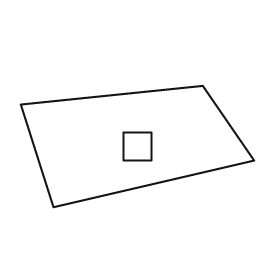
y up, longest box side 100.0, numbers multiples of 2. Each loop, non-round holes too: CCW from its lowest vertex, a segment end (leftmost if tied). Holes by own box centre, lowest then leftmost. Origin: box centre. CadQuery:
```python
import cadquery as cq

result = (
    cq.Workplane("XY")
    .moveTo(-36.0, -26.0)
    .lineTo(50.0, -6.0)
    .lineTo(28.0, 26.0)
    .lineTo(-50.0, 18.0)
    .close()
    .moveTo(-6.0, -6.0)
    .lineTo(6.0, -6.0)
    .lineTo(6.0, 6.0)
    .lineTo(-6.0, 6.0)
    .close()
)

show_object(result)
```